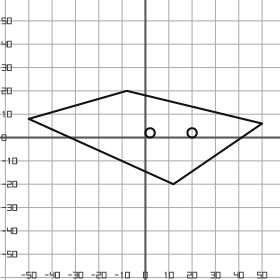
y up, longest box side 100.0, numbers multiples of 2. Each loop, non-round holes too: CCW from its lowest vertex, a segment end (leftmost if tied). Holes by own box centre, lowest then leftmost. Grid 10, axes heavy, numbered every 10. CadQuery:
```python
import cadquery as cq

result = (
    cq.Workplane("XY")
    .moveTo(12.0, -20.0)
    .lineTo(50.0, 6.0)
    .lineTo(-8.0, 20.0)
    .lineTo(-50.0, 8.0)
    .close()
    .moveTo(2.0, 2.0)
    .circle(2.0)
    .moveTo(20.0, 2.0)
    .circle(2.0)
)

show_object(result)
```